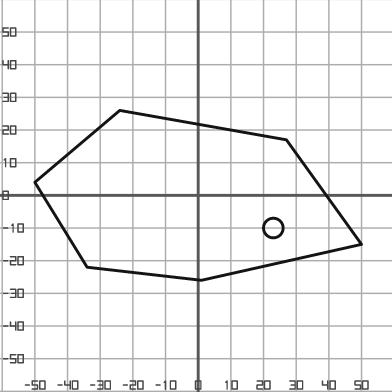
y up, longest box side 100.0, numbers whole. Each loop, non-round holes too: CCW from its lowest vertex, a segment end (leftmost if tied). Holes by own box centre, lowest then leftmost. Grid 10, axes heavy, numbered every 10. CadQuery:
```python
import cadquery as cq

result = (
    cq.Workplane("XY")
    .moveTo(1.0, -26.0)
    .lineTo(50.0, -15.0)
    .lineTo(27.0, 17.0)
    .lineTo(-24.0, 26.0)
    .lineTo(-50.0, 4.0)
    .lineTo(-34.0, -22.0)
    .close()
    .moveTo(23.0, -10.0)
    .circle(3.0)
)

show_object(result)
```